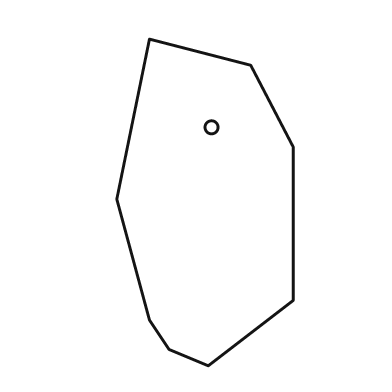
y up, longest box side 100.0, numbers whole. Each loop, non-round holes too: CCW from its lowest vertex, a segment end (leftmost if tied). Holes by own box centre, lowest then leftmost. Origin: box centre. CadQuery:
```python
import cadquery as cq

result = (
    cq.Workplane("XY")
    .moveTo(1.0, -50.0)
    .lineTo(27.0, -30.0)
    .lineTo(27.0, 17.0)
    .lineTo(14.0, 42.0)
    .lineTo(-17.0, 50.0)
    .lineTo(-27.0, 1.0)
    .lineTo(-17.0, -36.0)
    .lineTo(-11.0, -45.0)
    .close()
    .moveTo(2.0, 23.0)
    .circle(2.0)
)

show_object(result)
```